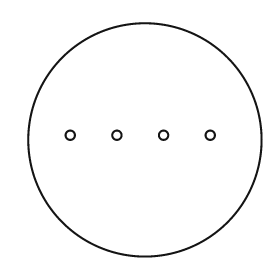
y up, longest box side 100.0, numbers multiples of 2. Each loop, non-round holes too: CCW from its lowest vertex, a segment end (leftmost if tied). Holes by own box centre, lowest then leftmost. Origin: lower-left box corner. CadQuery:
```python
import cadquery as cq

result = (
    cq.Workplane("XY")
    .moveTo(50.0, 50.0)
    .circle(50.0)
    .moveTo(18.0, 52.0)
    .circle(2.0)
    .moveTo(38.0, 52.0)
    .circle(2.0)
    .moveTo(58.0, 52.0)
    .circle(2.0)
    .moveTo(78.0, 52.0)
    .circle(2.0)
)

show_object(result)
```